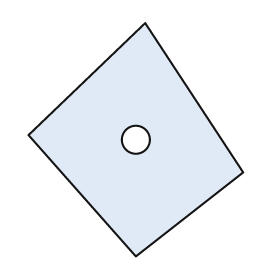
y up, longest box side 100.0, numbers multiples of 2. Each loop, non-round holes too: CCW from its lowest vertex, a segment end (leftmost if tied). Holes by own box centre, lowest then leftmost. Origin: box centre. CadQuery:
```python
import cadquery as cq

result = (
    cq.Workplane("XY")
    .moveTo(0.0, -50.0)
    .lineTo(46.0, -14.0)
    .lineTo(4.0, 50.0)
    .lineTo(-46.0, 2.0)
    .close()
    .moveTo(0.0, 0.0)
    .circle(6.0)
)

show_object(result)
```